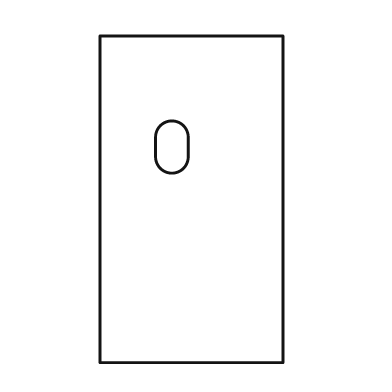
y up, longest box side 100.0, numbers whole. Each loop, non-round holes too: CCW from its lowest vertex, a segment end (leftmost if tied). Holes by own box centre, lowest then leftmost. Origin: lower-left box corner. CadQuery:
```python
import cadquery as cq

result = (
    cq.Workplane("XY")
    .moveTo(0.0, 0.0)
    .lineTo(56.0, 0.0)
    .lineTo(56.0, 100.0)
    .lineTo(0.0, 100.0)
    .close()
    .moveTo(17.0, 63.0)
    .threePointArc((22.0, 58.0), (27.0, 63.0))
    .lineTo(27.0, 69.0)
    .threePointArc((22.0, 74.0), (17.0, 69.0))
    .close()
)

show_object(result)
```